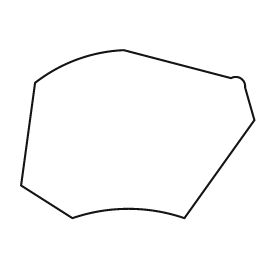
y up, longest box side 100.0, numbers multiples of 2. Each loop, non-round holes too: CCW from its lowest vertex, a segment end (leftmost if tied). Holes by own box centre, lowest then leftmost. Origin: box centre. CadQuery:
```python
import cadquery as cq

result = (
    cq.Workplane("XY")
    .moveTo(-28.0, -36.0)
    .threePointArc((-4.0, -32.0), (20.0, -36.0))
    .lineTo(50.0, 6.0)
    .lineTo(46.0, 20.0)
    .threePointArc((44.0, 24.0), (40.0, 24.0))
    .lineTo(-6.0, 36.0)
    .threePointArc((-26.0, 32.0), (-44.0, 22.0))
    .lineTo(-50.0, -22.0)
    .close()
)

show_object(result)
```